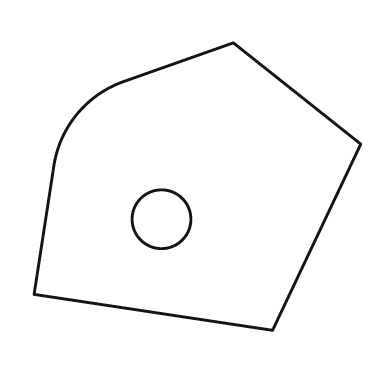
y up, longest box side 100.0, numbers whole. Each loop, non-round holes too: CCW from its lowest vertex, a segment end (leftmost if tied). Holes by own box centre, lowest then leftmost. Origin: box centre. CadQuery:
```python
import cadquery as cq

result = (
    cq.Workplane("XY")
    .moveTo(23.0, -44.0)
    .lineTo(50.0, 13.0)
    .lineTo(11.0, 44.0)
    .lineTo(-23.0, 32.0)
    .threePointArc((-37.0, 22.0), (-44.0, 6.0))
    .lineTo(-50.0, -33.0)
    .close()
    .moveTo(-11.0, -10.0)
    .circle(9.0)
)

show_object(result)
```